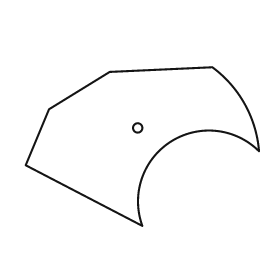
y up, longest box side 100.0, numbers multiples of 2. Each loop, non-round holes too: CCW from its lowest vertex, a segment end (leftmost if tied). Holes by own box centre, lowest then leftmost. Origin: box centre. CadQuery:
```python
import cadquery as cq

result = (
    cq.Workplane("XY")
    .moveTo(0.0, -34.0)
    .threePointArc((12.0, 2.0), (50.0, -2.0))
    .threePointArc((44.0, 18.0), (30.0, 34.0))
    .lineTo(-14.0, 32.0)
    .lineTo(-40.0, 16.0)
    .lineTo(-50.0, -8.0)
    .close()
    .moveTo(-2.0, 8.0)
    .circle(2.0)
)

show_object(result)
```